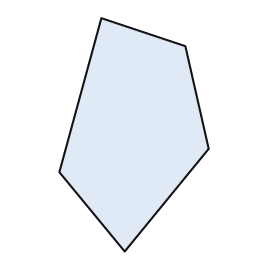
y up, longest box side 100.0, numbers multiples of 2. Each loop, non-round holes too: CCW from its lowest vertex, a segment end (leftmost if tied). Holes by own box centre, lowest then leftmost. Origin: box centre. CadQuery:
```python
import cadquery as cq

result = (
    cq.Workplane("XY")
    .moveTo(-4.0, -50.0)
    .lineTo(32.0, -6.0)
    .lineTo(22.0, 38.0)
    .lineTo(-14.0, 50.0)
    .lineTo(-32.0, -16.0)
    .close()
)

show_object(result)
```